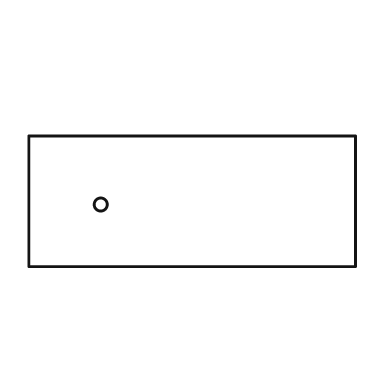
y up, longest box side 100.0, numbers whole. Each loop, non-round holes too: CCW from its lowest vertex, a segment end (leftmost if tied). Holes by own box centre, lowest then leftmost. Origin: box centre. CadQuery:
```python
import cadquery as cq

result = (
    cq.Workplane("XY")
    .moveTo(-50.0, -20.0)
    .lineTo(50.0, -20.0)
    .lineTo(50.0, 20.0)
    .lineTo(-50.0, 20.0)
    .close()
    .moveTo(-28.0, -1.0)
    .circle(2.0)
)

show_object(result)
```